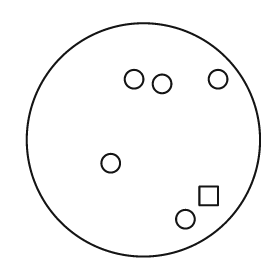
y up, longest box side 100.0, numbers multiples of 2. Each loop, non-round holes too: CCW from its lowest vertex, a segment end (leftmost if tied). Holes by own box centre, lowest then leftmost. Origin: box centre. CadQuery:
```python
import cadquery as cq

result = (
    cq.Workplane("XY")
    .moveTo(0.0, 0.0)
    .circle(50.0)
    .moveTo(18.0, -34.0)
    .circle(4.0)
    .moveTo(24.0, -28.0)
    .lineTo(32.0, -28.0)
    .lineTo(32.0, -20.0)
    .lineTo(24.0, -20.0)
    .close()
    .moveTo(-14.0, -10.0)
    .circle(4.0)
    .moveTo(8.0, 24.0)
    .circle(4.0)
    .moveTo(-4.0, 26.0)
    .circle(4.0)
    .moveTo(32.0, 26.0)
    .circle(4.0)
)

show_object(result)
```